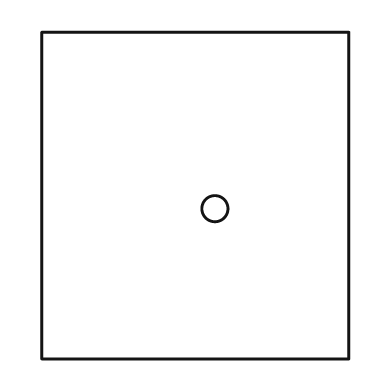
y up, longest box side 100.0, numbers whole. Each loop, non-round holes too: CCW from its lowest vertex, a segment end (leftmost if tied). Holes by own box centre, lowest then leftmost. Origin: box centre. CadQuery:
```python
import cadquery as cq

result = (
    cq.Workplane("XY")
    .moveTo(-47.0, -50.0)
    .lineTo(47.0, -50.0)
    .lineTo(47.0, 50.0)
    .lineTo(-47.0, 50.0)
    .close()
    .moveTo(6.0, -4.0)
    .circle(4.0)
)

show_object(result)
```